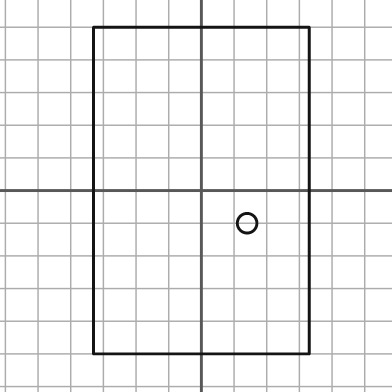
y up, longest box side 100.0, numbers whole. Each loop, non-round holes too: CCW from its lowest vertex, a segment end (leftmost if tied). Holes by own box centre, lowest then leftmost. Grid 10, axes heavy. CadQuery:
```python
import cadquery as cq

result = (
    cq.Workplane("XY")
    .moveTo(-33.0, -50.0)
    .lineTo(33.0, -50.0)
    .lineTo(33.0, 50.0)
    .lineTo(-33.0, 50.0)
    .close()
    .moveTo(14.0, -10.0)
    .circle(3.0)
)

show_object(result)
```